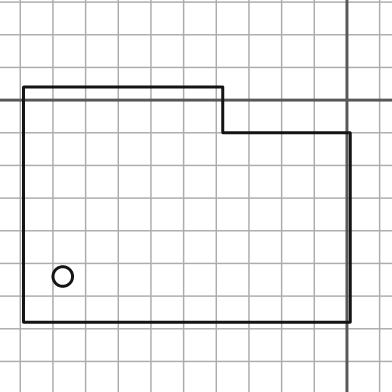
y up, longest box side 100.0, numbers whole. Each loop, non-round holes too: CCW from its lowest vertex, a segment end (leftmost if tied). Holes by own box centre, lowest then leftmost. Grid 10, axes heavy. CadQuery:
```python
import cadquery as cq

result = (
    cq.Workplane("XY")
    .moveTo(-99.0, -68.0)
    .lineTo(1.0, -68.0)
    .lineTo(1.0, -10.0)
    .lineTo(-38.0, -10.0)
    .lineTo(-38.0, 4.0)
    .lineTo(-99.0, 4.0)
    .close()
    .moveTo(-87.0, -54.0)
    .circle(3.0)
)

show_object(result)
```